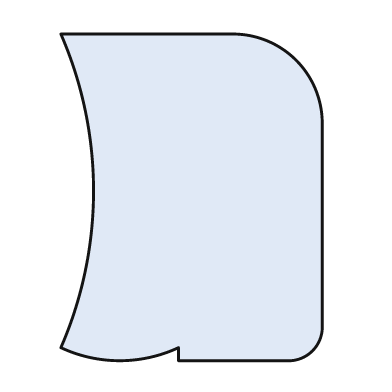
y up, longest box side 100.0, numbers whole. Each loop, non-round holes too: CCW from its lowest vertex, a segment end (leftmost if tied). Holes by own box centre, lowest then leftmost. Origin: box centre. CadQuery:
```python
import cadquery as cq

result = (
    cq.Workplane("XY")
    .moveTo(-4.0, -50.0)
    .lineTo(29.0, -50.0)
    .threePointArc((37.0, -47.0), (40.0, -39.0))
    .lineTo(40.0, 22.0)
    .threePointArc((32.0, 42.0), (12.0, 50.0))
    .lineTo(-40.0, 50.0)
    .threePointArc((-30.0, 2.0), (-40.0, -46.0))
    .threePointArc((-22.0, -50.0), (-4.0, -46.0))
    .close()
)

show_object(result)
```